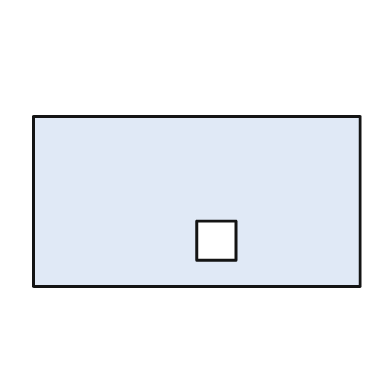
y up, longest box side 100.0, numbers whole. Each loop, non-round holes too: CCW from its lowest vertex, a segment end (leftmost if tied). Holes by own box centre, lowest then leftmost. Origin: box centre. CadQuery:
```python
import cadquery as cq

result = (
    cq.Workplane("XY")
    .moveTo(-50.0, -26.0)
    .lineTo(50.0, -26.0)
    .lineTo(50.0, 26.0)
    .lineTo(-50.0, 26.0)
    .close()
    .moveTo(0.0, -18.0)
    .lineTo(12.0, -18.0)
    .lineTo(12.0, -6.0)
    .lineTo(0.0, -6.0)
    .close()
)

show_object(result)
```